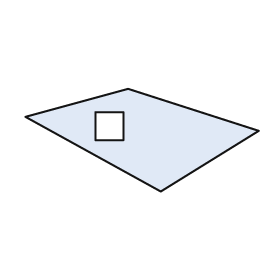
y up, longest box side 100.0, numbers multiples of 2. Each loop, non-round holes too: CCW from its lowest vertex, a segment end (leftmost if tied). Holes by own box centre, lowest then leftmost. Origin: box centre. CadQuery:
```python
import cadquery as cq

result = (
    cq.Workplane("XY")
    .moveTo(8.0, -22.0)
    .lineTo(50.0, 4.0)
    .lineTo(-6.0, 22.0)
    .lineTo(-50.0, 10.0)
    .close()
    .moveTo(-20.0, 0.0)
    .lineTo(-8.0, 0.0)
    .lineTo(-8.0, 12.0)
    .lineTo(-20.0, 12.0)
    .close()
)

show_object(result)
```